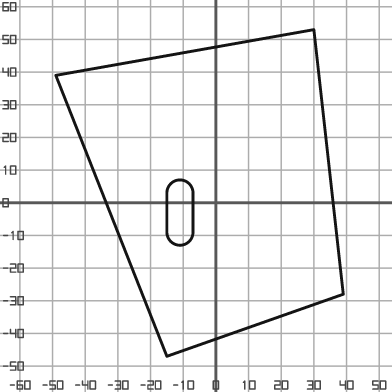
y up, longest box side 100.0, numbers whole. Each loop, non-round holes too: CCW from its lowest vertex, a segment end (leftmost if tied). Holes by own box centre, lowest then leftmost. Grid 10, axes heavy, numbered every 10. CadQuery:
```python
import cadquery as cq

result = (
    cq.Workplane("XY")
    .moveTo(-15.0, -47.0)
    .lineTo(39.0, -28.0)
    .lineTo(30.0, 53.0)
    .lineTo(-49.0, 39.0)
    .close()
    .moveTo(-15.0, -9.0)
    .threePointArc((-11.0, -13.0), (-7.0, -9.0))
    .lineTo(-7.0, 3.0)
    .threePointArc((-11.0, 7.0), (-15.0, 3.0))
    .close()
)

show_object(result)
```